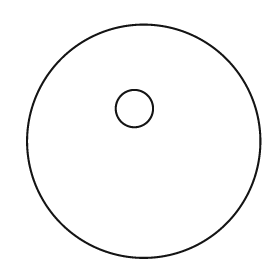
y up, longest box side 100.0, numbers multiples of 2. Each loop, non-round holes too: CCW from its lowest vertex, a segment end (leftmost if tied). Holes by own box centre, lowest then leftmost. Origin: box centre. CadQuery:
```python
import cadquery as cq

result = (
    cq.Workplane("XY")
    .moveTo(0.0, 0.0)
    .circle(50.0)
    .moveTo(-4.0, 14.0)
    .circle(8.0)
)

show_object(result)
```